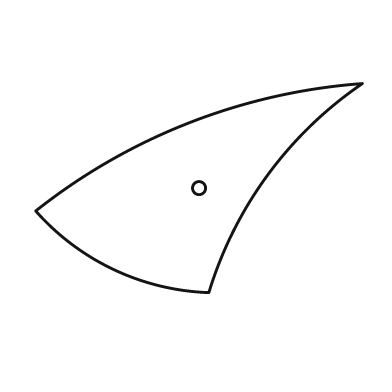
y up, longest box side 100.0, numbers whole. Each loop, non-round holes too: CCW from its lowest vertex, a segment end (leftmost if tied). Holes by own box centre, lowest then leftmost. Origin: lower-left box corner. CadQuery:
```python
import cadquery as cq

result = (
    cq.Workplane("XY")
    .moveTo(53.0, 0.0)
    .threePointArc((71.0, 36.0), (100.0, 64.0))
    .threePointArc((47.0, 52.0), (0.0, 25.0))
    .threePointArc((24.0, 7.0), (53.0, 0.0))
    .close()
    .moveTo(50.0, 32.0)
    .circle(2.0)
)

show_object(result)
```